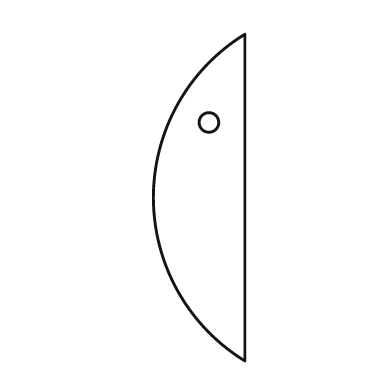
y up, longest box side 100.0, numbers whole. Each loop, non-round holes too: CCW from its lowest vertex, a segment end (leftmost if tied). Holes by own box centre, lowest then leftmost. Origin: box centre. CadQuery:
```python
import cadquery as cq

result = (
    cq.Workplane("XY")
    .moveTo(14.0, -50.0)
    .lineTo(14.0, 50.0)
    .threePointArc((-14.0, 0.0), (14.0, -50.0))
    .close()
    .moveTo(3.0, 23.0)
    .circle(3.0)
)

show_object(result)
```